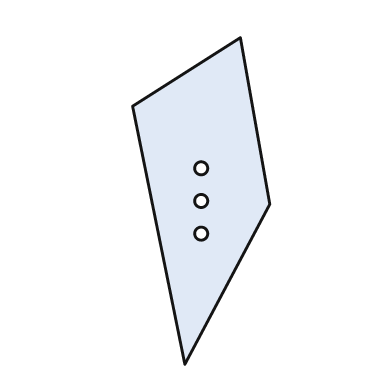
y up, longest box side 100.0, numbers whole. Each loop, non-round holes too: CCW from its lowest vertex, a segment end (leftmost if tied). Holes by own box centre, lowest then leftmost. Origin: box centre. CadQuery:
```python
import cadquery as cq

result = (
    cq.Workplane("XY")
    .moveTo(-5.0, -50.0)
    .lineTo(21.0, -1.0)
    .lineTo(12.0, 50.0)
    .lineTo(-21.0, 29.0)
    .close()
    .moveTo(0.0, -10.0)
    .circle(2.0)
    .moveTo(0.0, 0.0)
    .circle(2.0)
    .moveTo(0.0, 10.0)
    .circle(2.0)
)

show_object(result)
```